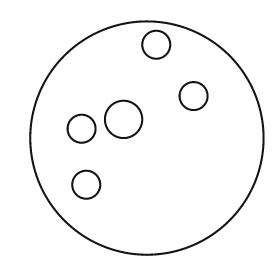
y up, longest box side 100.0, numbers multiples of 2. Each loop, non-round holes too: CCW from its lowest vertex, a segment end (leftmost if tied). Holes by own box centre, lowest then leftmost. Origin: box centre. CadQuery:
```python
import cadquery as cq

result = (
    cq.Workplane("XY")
    .moveTo(0.0, 0.0)
    .circle(50.0)
    .moveTo(-26.0, -20.0)
    .circle(6.0)
    .moveTo(-28.0, 4.0)
    .circle(6.0)
    .moveTo(-10.0, 8.0)
    .circle(8.0)
    .moveTo(20.0, 18.0)
    .circle(6.0)
    .moveTo(4.0, 40.0)
    .circle(6.0)
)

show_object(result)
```